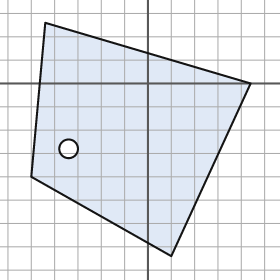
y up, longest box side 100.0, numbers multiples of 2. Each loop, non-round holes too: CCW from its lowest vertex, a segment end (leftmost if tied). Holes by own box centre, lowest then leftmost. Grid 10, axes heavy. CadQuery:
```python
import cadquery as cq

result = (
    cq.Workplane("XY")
    .moveTo(10.0, -74.0)
    .lineTo(44.0, 0.0)
    .lineTo(-44.0, 26.0)
    .lineTo(-50.0, -40.0)
    .close()
    .moveTo(-34.0, -28.0)
    .circle(4.0)
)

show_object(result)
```